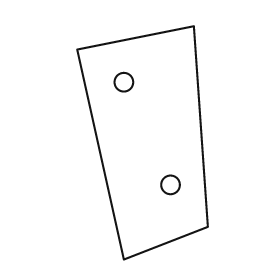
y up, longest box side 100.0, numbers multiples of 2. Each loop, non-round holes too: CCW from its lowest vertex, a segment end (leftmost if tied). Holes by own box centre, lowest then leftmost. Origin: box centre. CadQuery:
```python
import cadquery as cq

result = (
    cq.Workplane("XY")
    .moveTo(-8.0, -50.0)
    .lineTo(28.0, -36.0)
    .lineTo(22.0, 50.0)
    .lineTo(-28.0, 40.0)
    .close()
    .moveTo(12.0, -18.0)
    .circle(4.0)
    .moveTo(-8.0, 26.0)
    .circle(4.0)
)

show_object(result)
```